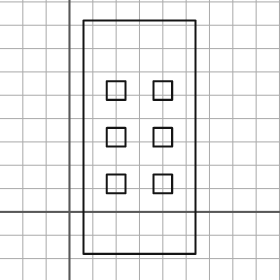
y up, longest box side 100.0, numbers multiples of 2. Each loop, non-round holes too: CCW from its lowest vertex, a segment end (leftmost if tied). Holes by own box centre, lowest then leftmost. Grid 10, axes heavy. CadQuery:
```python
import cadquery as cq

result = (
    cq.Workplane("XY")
    .moveTo(6.0, -18.0)
    .lineTo(54.0, -18.0)
    .lineTo(54.0, 82.0)
    .lineTo(6.0, 82.0)
    .close()
    .moveTo(16.0, 8.0)
    .lineTo(24.0, 8.0)
    .lineTo(24.0, 16.0)
    .lineTo(16.0, 16.0)
    .close()
    .moveTo(36.0, 8.0)
    .lineTo(44.0, 8.0)
    .lineTo(44.0, 16.0)
    .lineTo(36.0, 16.0)
    .close()
    .moveTo(16.0, 28.0)
    .lineTo(24.0, 28.0)
    .lineTo(24.0, 36.0)
    .lineTo(16.0, 36.0)
    .close()
    .moveTo(36.0, 28.0)
    .lineTo(44.0, 28.0)
    .lineTo(44.0, 36.0)
    .lineTo(36.0, 36.0)
    .close()
    .moveTo(16.0, 48.0)
    .lineTo(24.0, 48.0)
    .lineTo(24.0, 56.0)
    .lineTo(16.0, 56.0)
    .close()
    .moveTo(36.0, 48.0)
    .lineTo(44.0, 48.0)
    .lineTo(44.0, 56.0)
    .lineTo(36.0, 56.0)
    .close()
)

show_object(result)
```